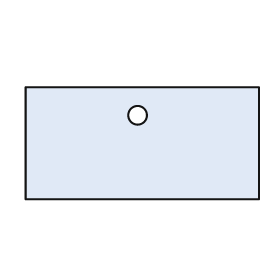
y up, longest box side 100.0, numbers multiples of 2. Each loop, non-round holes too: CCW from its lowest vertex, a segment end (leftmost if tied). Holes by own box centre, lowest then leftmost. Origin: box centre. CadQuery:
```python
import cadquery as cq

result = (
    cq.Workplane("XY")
    .moveTo(-50.0, -24.0)
    .lineTo(50.0, -24.0)
    .lineTo(50.0, 24.0)
    .lineTo(-50.0, 24.0)
    .close()
    .moveTo(-2.0, 12.0)
    .circle(4.0)
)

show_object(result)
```